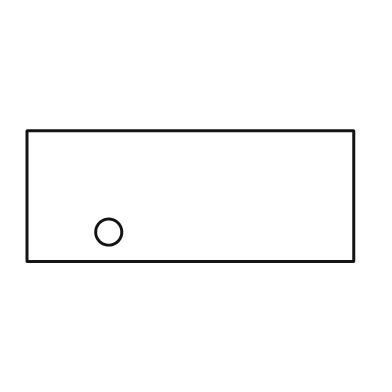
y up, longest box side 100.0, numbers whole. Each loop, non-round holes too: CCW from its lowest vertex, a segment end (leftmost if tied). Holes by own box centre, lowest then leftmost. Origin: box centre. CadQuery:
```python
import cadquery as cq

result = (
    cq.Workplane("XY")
    .moveTo(-50.0, -20.0)
    .lineTo(50.0, -20.0)
    .lineTo(50.0, 20.0)
    .lineTo(-50.0, 20.0)
    .close()
    .moveTo(-25.0, -11.0)
    .circle(4.0)
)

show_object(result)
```